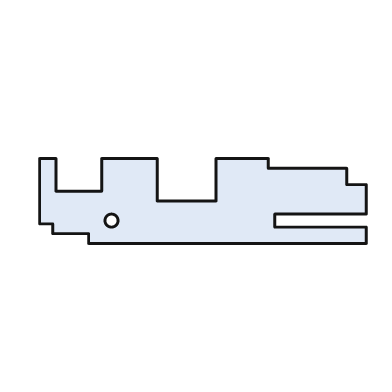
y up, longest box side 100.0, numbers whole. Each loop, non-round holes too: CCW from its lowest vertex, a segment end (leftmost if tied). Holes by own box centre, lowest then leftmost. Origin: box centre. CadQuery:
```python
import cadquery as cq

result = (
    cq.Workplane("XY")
    .moveTo(-35.0, -13.0)
    .lineTo(50.0, -13.0)
    .lineTo(50.0, -8.0)
    .lineTo(22.0, -8.0)
    .lineTo(22.0, -4.0)
    .lineTo(50.0, -4.0)
    .lineTo(50.0, 5.0)
    .lineTo(44.0, 5.0)
    .lineTo(44.0, 10.0)
    .lineTo(20.0, 10.0)
    .lineTo(20.0, 13.0)
    .lineTo(4.0, 13.0)
    .lineTo(4.0, 0.0)
    .lineTo(-14.0, 0.0)
    .lineTo(-14.0, 13.0)
    .lineTo(-31.0, 13.0)
    .lineTo(-31.0, 3.0)
    .lineTo(-45.0, 3.0)
    .lineTo(-45.0, 13.0)
    .lineTo(-50.0, 13.0)
    .lineTo(-50.0, -7.0)
    .lineTo(-46.0, -7.0)
    .lineTo(-46.0, -10.0)
    .lineTo(-35.0, -10.0)
    .close()
    .moveTo(-28.0, -6.0)
    .circle(2.0)
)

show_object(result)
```